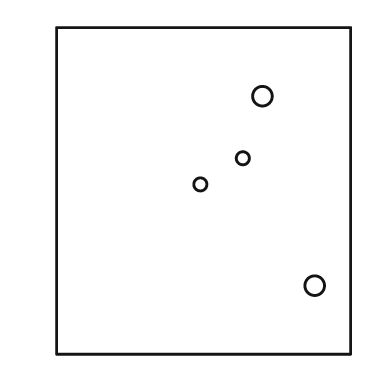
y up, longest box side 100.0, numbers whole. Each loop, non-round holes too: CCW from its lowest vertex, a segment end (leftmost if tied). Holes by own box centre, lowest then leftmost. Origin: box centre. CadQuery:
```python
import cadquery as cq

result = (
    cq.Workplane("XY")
    .moveTo(-45.0, -50.0)
    .lineTo(45.0, -50.0)
    .lineTo(45.0, 50.0)
    .lineTo(-45.0, 50.0)
    .close()
    .moveTo(34.0, -29.0)
    .circle(3.0)
    .moveTo(-1.0, 2.0)
    .circle(2.0)
    .moveTo(12.0, 10.0)
    .circle(2.0)
    .moveTo(18.0, 29.0)
    .circle(3.0)
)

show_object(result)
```